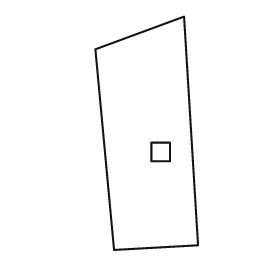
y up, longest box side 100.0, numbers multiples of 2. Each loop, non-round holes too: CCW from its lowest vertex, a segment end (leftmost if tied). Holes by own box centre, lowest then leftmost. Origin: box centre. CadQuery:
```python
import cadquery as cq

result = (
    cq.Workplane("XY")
    .moveTo(-14.0, -50.0)
    .lineTo(22.0, -48.0)
    .lineTo(16.0, 50.0)
    .lineTo(-22.0, 36.0)
    .close()
    .moveTo(2.0, -12.0)
    .lineTo(10.0, -12.0)
    .lineTo(10.0, -4.0)
    .lineTo(2.0, -4.0)
    .close()
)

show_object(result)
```